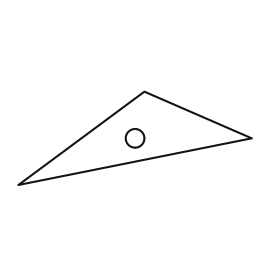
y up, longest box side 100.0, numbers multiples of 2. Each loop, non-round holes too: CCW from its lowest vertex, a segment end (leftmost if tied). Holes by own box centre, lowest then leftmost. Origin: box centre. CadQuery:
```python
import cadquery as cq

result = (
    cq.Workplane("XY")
    .moveTo(-50.0, -20.0)
    .lineTo(50.0, 0.0)
    .lineTo(4.0, 20.0)
    .close()
    .moveTo(0.0, 0.0)
    .circle(4.0)
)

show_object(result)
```